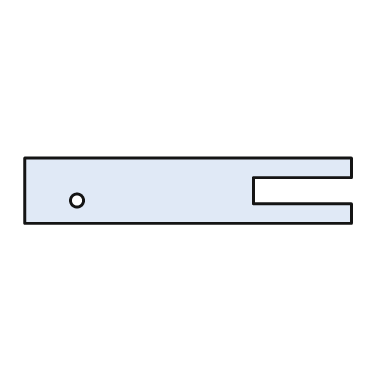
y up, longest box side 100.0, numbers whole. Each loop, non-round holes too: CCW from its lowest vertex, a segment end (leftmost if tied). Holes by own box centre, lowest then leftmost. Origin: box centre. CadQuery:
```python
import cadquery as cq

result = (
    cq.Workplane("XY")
    .moveTo(-50.0, -10.0)
    .lineTo(50.0, -10.0)
    .lineTo(50.0, -4.0)
    .lineTo(20.0, -4.0)
    .lineTo(20.0, 4.0)
    .lineTo(50.0, 4.0)
    .lineTo(50.0, 10.0)
    .lineTo(-50.0, 10.0)
    .close()
    .moveTo(-34.0, -3.0)
    .circle(2.0)
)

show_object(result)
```